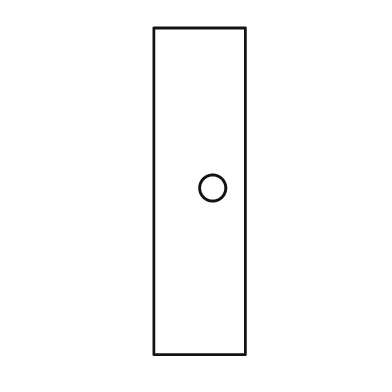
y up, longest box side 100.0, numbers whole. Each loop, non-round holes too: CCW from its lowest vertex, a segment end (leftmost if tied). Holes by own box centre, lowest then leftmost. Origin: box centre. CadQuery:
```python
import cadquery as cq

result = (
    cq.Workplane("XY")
    .moveTo(-14.0, -50.0)
    .lineTo(14.0, -50.0)
    .lineTo(14.0, 50.0)
    .lineTo(-14.0, 50.0)
    .close()
    .moveTo(4.0, 1.0)
    .circle(4.0)
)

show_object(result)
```